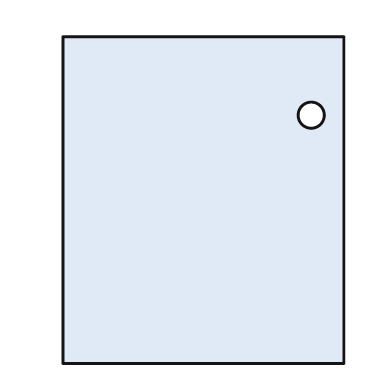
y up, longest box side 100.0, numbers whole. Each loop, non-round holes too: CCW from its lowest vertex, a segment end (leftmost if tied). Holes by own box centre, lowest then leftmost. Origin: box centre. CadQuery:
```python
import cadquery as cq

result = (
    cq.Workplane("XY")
    .moveTo(-43.0, -50.0)
    .lineTo(43.0, -50.0)
    .lineTo(43.0, 50.0)
    .lineTo(-43.0, 50.0)
    .close()
    .moveTo(33.0, 26.0)
    .circle(4.0)
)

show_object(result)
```